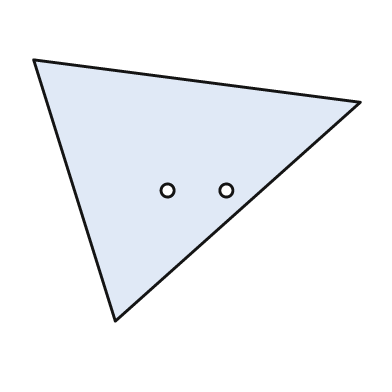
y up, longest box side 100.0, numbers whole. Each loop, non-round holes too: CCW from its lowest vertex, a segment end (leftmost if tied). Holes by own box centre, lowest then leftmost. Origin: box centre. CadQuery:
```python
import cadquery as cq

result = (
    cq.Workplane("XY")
    .moveTo(-25.0, -40.0)
    .lineTo(50.0, 27.0)
    .lineTo(-50.0, 40.0)
    .close()
    .moveTo(-9.0, 0.0)
    .circle(2.0)
    .moveTo(9.0, 0.0)
    .circle(2.0)
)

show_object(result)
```